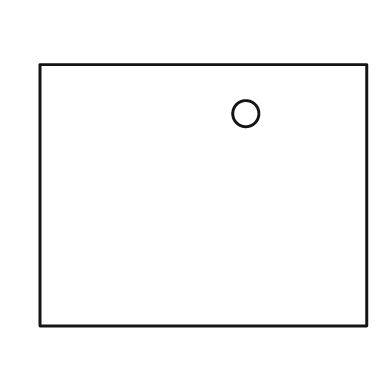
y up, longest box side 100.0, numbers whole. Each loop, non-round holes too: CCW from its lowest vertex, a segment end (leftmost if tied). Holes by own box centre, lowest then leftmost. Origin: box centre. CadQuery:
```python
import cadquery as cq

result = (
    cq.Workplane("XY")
    .moveTo(-50.0, -40.0)
    .lineTo(50.0, -40.0)
    .lineTo(50.0, 40.0)
    .lineTo(-50.0, 40.0)
    .close()
    .moveTo(13.0, 25.0)
    .circle(4.0)
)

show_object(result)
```